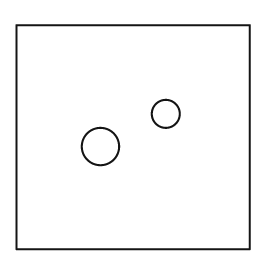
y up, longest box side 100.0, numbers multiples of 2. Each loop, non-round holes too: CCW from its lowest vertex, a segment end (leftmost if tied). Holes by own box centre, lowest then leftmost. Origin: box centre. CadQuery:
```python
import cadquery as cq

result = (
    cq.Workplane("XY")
    .moveTo(-50.0, -48.0)
    .lineTo(50.0, -48.0)
    .lineTo(50.0, 48.0)
    .lineTo(-50.0, 48.0)
    .close()
    .moveTo(-14.0, -4.0)
    .circle(8.0)
    .moveTo(14.0, 10.0)
    .circle(6.0)
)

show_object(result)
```